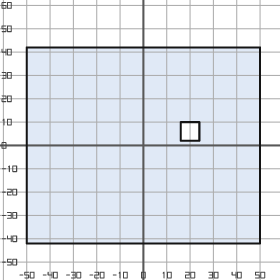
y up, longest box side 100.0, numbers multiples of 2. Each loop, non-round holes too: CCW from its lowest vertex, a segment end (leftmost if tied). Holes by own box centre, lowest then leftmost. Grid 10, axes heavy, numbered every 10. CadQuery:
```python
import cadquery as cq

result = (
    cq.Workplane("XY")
    .moveTo(-50.0, -42.0)
    .lineTo(50.0, -42.0)
    .lineTo(50.0, 42.0)
    .lineTo(-50.0, 42.0)
    .close()
    .moveTo(16.0, 2.0)
    .lineTo(24.0, 2.0)
    .lineTo(24.0, 10.0)
    .lineTo(16.0, 10.0)
    .close()
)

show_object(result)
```